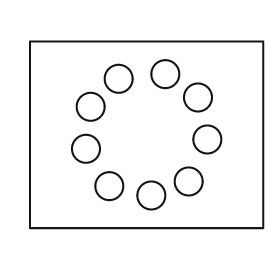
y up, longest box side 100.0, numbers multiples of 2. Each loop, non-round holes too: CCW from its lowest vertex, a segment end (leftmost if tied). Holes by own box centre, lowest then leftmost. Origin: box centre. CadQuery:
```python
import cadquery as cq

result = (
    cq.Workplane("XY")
    .moveTo(-50.0, -40.0)
    .lineTo(50.0, -40.0)
    .lineTo(50.0, 40.0)
    .lineTo(-50.0, 40.0)
    .close()
    .moveTo(2.0, -26.0)
    .circle(6.0)
    .moveTo(-16.0, -22.0)
    .circle(6.0)
    .moveTo(18.0, -20.0)
    .circle(6.0)
    .moveTo(-26.0, -6.0)
    .circle(6.0)
    .moveTo(26.0, -2.0)
    .circle(6.0)
    .moveTo(-24.0, 12.0)
    .circle(6.0)
    .moveTo(22.0, 16.0)
    .circle(6.0)
    .moveTo(-12.0, 24.0)
    .circle(6.0)
    .moveTo(8.0, 26.0)
    .circle(6.0)
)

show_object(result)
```